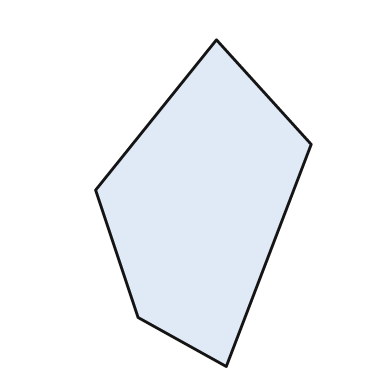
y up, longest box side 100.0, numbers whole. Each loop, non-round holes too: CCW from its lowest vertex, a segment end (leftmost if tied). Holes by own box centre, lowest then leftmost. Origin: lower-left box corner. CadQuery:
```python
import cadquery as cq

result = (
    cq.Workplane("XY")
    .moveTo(40.0, 0.0)
    .lineTo(66.0, 68.0)
    .lineTo(37.0, 100.0)
    .lineTo(0.0, 54.0)
    .lineTo(13.0, 15.0)
    .close()
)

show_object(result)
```